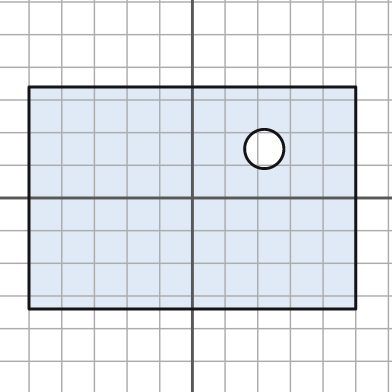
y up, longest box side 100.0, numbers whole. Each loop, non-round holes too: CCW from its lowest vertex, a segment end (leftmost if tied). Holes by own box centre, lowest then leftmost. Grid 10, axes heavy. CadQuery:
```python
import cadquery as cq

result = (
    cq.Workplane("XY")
    .moveTo(-50.0, -34.0)
    .lineTo(50.0, -34.0)
    .lineTo(50.0, 34.0)
    .lineTo(-50.0, 34.0)
    .close()
    .moveTo(22.0, 15.0)
    .circle(6.0)
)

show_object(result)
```